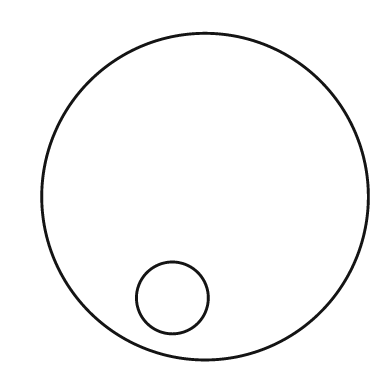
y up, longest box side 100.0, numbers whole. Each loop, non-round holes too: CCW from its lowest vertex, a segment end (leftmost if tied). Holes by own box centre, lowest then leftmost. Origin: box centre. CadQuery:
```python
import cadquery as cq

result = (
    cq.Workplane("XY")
    .moveTo(0.0, 0.0)
    .circle(50.0)
    .moveTo(-10.0, -31.0)
    .circle(11.0)
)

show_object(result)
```